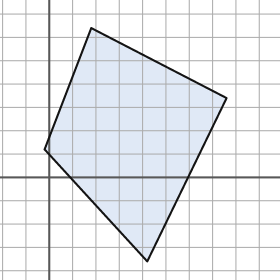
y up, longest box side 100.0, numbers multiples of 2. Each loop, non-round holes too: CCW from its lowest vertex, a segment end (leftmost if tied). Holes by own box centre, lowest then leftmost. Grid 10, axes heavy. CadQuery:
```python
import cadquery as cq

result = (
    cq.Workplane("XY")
    .moveTo(42.0, -36.0)
    .lineTo(76.0, 34.0)
    .lineTo(18.0, 64.0)
    .lineTo(-2.0, 12.0)
    .close()
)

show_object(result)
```